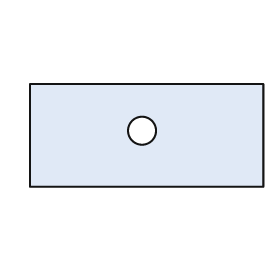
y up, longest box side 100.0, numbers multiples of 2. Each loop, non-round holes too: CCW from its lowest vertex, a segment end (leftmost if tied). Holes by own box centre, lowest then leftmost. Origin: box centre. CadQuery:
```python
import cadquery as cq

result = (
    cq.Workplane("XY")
    .moveTo(-50.0, -22.0)
    .lineTo(50.0, -22.0)
    .lineTo(50.0, 22.0)
    .lineTo(-50.0, 22.0)
    .close()
    .moveTo(-2.0, 2.0)
    .circle(6.0)
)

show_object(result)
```